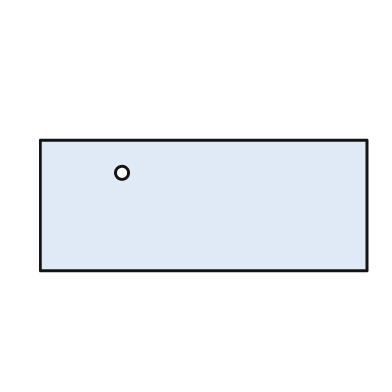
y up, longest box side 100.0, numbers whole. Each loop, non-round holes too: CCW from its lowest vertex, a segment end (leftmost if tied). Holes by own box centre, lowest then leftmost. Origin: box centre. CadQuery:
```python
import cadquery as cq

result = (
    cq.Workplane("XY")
    .moveTo(-50.0, -20.0)
    .lineTo(50.0, -20.0)
    .lineTo(50.0, 20.0)
    .lineTo(-50.0, 20.0)
    .close()
    .moveTo(-25.0, 10.0)
    .circle(2.0)
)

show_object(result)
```